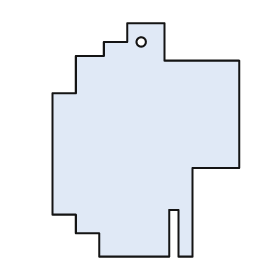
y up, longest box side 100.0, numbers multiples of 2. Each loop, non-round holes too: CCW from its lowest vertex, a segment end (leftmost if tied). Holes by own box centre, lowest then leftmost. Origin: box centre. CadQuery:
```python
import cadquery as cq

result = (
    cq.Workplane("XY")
    .moveTo(-20.0, -50.0)
    .lineTo(10.0, -50.0)
    .lineTo(10.0, -30.0)
    .lineTo(14.0, -30.0)
    .lineTo(14.0, -50.0)
    .lineTo(20.0, -50.0)
    .lineTo(20.0, -12.0)
    .lineTo(40.0, -12.0)
    .lineTo(40.0, 34.0)
    .lineTo(8.0, 34.0)
    .lineTo(8.0, 50.0)
    .lineTo(-8.0, 50.0)
    .lineTo(-8.0, 42.0)
    .lineTo(-18.0, 42.0)
    .lineTo(-18.0, 36.0)
    .lineTo(-30.0, 36.0)
    .lineTo(-30.0, 20.0)
    .lineTo(-40.0, 20.0)
    .lineTo(-40.0, -32.0)
    .lineTo(-30.0, -32.0)
    .lineTo(-30.0, -40.0)
    .lineTo(-20.0, -40.0)
    .close()
    .moveTo(-2.0, 42.0)
    .circle(2.0)
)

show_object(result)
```